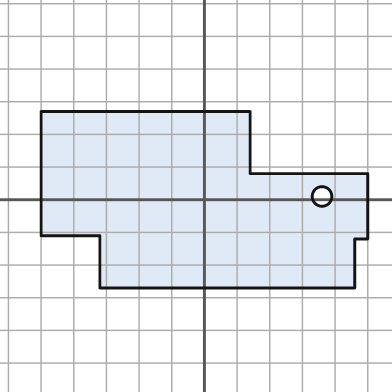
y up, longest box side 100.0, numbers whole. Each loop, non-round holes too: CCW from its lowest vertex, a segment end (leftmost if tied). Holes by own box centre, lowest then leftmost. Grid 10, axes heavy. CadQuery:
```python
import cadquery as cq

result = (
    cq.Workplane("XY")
    .moveTo(-32.0, -27.0)
    .lineTo(46.0, -27.0)
    .lineTo(46.0, -12.0)
    .lineTo(50.0, -12.0)
    .lineTo(50.0, 8.0)
    .lineTo(14.0, 8.0)
    .lineTo(14.0, 27.0)
    .lineTo(-50.0, 27.0)
    .lineTo(-50.0, -11.0)
    .lineTo(-32.0, -11.0)
    .close()
    .moveTo(36.0, 1.0)
    .circle(3.0)
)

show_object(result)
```